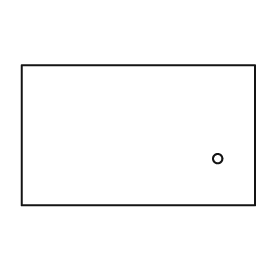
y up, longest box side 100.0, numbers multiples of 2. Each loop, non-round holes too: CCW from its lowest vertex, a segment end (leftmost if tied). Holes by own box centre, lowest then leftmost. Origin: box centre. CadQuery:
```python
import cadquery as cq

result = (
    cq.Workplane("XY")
    .moveTo(-50.0, -30.0)
    .lineTo(50.0, -30.0)
    .lineTo(50.0, 30.0)
    .lineTo(-50.0, 30.0)
    .close()
    .moveTo(34.0, -10.0)
    .circle(2.0)
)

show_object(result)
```